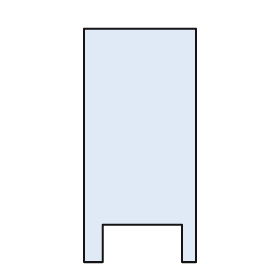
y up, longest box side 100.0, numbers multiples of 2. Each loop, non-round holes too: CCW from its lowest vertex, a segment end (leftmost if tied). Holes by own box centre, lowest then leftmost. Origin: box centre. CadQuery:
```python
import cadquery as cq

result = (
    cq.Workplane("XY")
    .moveTo(-24.0, -50.0)
    .lineTo(-16.0, -50.0)
    .lineTo(-16.0, -34.0)
    .lineTo(18.0, -34.0)
    .lineTo(18.0, -50.0)
    .lineTo(24.0, -50.0)
    .lineTo(24.0, 50.0)
    .lineTo(-24.0, 50.0)
    .close()
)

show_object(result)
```